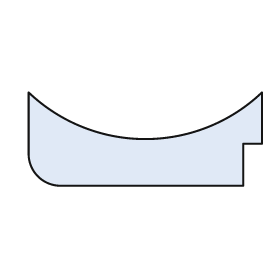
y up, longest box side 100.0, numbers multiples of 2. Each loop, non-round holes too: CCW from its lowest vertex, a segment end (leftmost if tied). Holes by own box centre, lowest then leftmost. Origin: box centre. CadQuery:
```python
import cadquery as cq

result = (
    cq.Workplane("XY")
    .moveTo(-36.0, -20.0)
    .lineTo(42.0, -20.0)
    .lineTo(42.0, -2.0)
    .lineTo(50.0, -2.0)
    .lineTo(50.0, 20.0)
    .threePointArc((0.0, 0.0), (-50.0, 20.0))
    .lineTo(-50.0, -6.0)
    .threePointArc((-46.0, -16.0), (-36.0, -20.0))
    .close()
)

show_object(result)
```